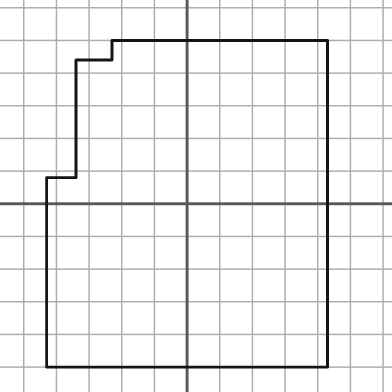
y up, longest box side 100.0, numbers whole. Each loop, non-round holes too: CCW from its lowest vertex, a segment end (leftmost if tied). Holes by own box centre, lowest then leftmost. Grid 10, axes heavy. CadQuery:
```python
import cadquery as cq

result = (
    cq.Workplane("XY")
    .moveTo(-43.0, -50.0)
    .lineTo(43.0, -50.0)
    .lineTo(43.0, 50.0)
    .lineTo(-23.0, 50.0)
    .lineTo(-23.0, 44.0)
    .lineTo(-34.0, 44.0)
    .lineTo(-34.0, 8.0)
    .lineTo(-43.0, 8.0)
    .close()
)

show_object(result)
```